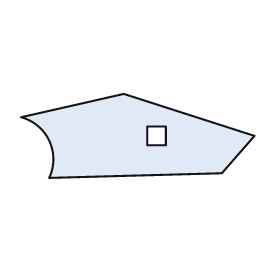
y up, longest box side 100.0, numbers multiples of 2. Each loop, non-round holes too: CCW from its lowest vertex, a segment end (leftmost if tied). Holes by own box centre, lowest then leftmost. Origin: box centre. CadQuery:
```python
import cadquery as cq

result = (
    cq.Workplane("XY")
    .moveTo(-38.0, -18.0)
    .lineTo(36.0, -16.0)
    .lineTo(50.0, 0.0)
    .lineTo(-6.0, 18.0)
    .lineTo(-50.0, 8.0)
    .threePointArc((-38.0, -2.0), (-38.0, -18.0))
    .close()
    .moveTo(4.0, -4.0)
    .lineTo(12.0, -4.0)
    .lineTo(12.0, 4.0)
    .lineTo(4.0, 4.0)
    .close()
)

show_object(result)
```